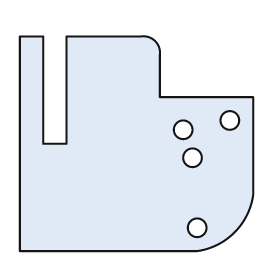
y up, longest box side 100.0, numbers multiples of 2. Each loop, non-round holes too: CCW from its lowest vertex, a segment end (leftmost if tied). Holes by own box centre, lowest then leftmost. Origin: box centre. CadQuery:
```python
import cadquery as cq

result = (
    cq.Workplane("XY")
    .moveTo(-50.0, -46.0)
    .lineTo(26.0, -46.0)
    .threePointArc((42.0, -38.0), (50.0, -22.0))
    .lineTo(50.0, 20.0)
    .lineTo(10.0, 20.0)
    .lineTo(10.0, 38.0)
    .threePointArc((8.0, 44.0), (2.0, 46.0))
    .lineTo(-30.0, 46.0)
    .lineTo(-30.0, 0.0)
    .lineTo(-40.0, 0.0)
    .lineTo(-40.0, 46.0)
    .lineTo(-50.0, 46.0)
    .close()
    .moveTo(26.0, -36.0)
    .circle(4.0)
    .moveTo(24.0, -6.0)
    .circle(4.0)
    .moveTo(20.0, 6.0)
    .circle(4.0)
    .moveTo(40.0, 10.0)
    .circle(4.0)
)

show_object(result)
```